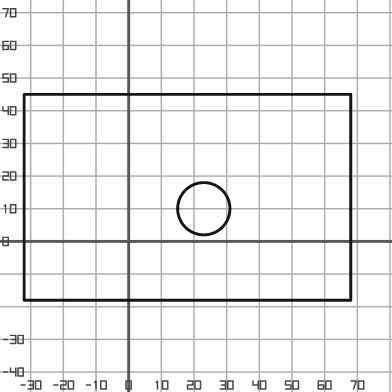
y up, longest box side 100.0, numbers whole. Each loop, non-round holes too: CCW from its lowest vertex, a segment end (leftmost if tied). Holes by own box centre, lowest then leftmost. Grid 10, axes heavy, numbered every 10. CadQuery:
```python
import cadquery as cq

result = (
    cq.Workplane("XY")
    .moveTo(-32.0, -18.0)
    .lineTo(68.0, -18.0)
    .lineTo(68.0, 45.0)
    .lineTo(-32.0, 45.0)
    .close()
    .moveTo(23.0, 10.0)
    .circle(8.0)
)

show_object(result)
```